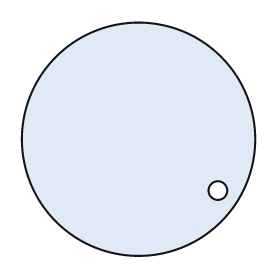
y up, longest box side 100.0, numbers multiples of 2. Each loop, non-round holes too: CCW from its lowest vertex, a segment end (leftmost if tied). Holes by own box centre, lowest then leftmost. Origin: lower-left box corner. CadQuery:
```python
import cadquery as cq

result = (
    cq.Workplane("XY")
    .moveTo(50.0, 50.0)
    .circle(50.0)
    .moveTo(84.0, 28.0)
    .circle(4.0)
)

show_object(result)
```